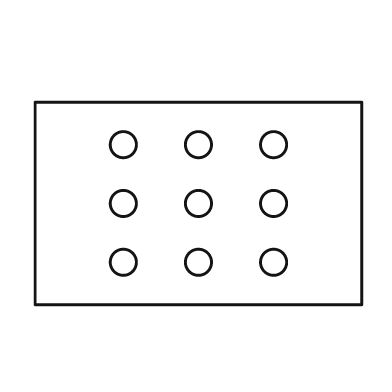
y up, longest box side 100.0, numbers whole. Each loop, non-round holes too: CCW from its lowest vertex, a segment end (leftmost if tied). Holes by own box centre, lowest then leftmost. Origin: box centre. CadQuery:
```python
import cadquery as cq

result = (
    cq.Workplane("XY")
    .moveTo(-50.0, -31.0)
    .lineTo(50.0, -31.0)
    .lineTo(50.0, 31.0)
    .lineTo(-50.0, 31.0)
    .close()
    .moveTo(-23.0, -18.0)
    .circle(4.0)
    .moveTo(0.0, -18.0)
    .circle(4.0)
    .moveTo(23.0, -18.0)
    .circle(4.0)
    .moveTo(-23.0, 0.0)
    .circle(4.0)
    .moveTo(0.0, 0.0)
    .circle(4.0)
    .moveTo(23.0, 0.0)
    .circle(4.0)
    .moveTo(-23.0, 18.0)
    .circle(4.0)
    .moveTo(0.0, 18.0)
    .circle(4.0)
    .moveTo(23.0, 18.0)
    .circle(4.0)
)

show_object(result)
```